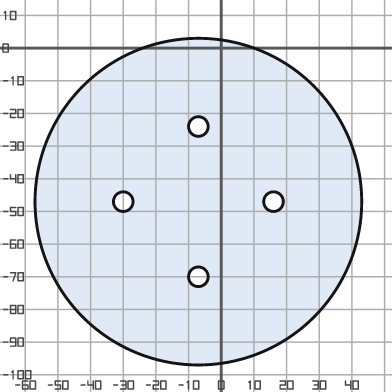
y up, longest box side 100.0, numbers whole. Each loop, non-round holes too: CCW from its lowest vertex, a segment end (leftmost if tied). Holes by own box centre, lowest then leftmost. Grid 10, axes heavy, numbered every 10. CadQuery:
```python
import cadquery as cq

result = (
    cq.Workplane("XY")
    .moveTo(-7.0, -47.0)
    .circle(50.0)
    .moveTo(-7.0, -70.0)
    .circle(3.0)
    .moveTo(-30.0, -47.0)
    .circle(3.0)
    .moveTo(16.0, -47.0)
    .circle(3.0)
    .moveTo(-7.0, -24.0)
    .circle(3.0)
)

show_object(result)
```